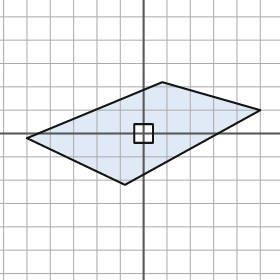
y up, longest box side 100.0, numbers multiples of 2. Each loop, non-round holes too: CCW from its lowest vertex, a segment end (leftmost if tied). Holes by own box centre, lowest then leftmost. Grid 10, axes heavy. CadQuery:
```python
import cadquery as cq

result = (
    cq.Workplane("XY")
    .moveTo(-8.0, -22.0)
    .lineTo(50.0, 10.0)
    .lineTo(8.0, 22.0)
    .lineTo(-50.0, -2.0)
    .close()
    .moveTo(-4.0, -4.0)
    .lineTo(4.0, -4.0)
    .lineTo(4.0, 4.0)
    .lineTo(-4.0, 4.0)
    .close()
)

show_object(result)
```